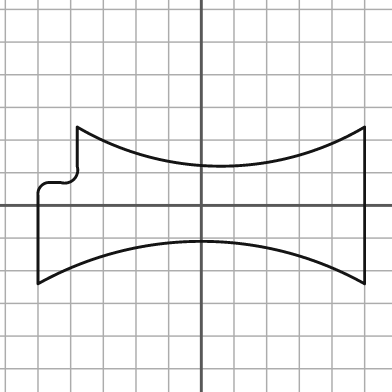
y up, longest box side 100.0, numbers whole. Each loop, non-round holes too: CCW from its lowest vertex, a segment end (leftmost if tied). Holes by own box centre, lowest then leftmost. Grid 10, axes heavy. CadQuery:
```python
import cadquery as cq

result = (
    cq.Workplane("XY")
    .moveTo(-50.0, -24.0)
    .threePointArc((0.0, -11.0), (50.0, -24.0))
    .lineTo(50.0, 24.0)
    .threePointArc((6.0, 12.0), (-38.0, 24.0))
    .lineTo(-38.0, 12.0)
    .threePointArc((-39.0, 8.0), (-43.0, 7.0))
    .lineTo(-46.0, 7.0)
    .threePointArc((-49.0, 6.0), (-50.0, 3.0))
    .close()
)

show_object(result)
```